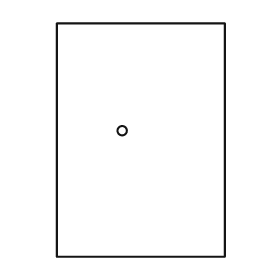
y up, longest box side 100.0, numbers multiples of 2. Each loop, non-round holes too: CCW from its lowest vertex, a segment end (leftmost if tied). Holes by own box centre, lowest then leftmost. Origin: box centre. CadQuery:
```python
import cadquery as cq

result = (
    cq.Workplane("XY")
    .moveTo(-36.0, -50.0)
    .lineTo(36.0, -50.0)
    .lineTo(36.0, 50.0)
    .lineTo(-36.0, 50.0)
    .close()
    .moveTo(-8.0, 4.0)
    .circle(2.0)
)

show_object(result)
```